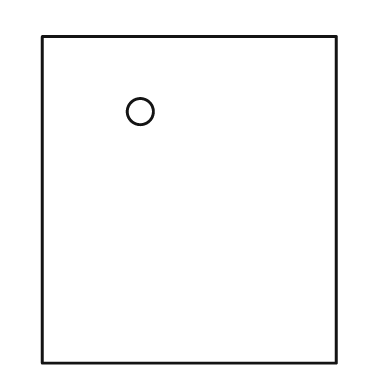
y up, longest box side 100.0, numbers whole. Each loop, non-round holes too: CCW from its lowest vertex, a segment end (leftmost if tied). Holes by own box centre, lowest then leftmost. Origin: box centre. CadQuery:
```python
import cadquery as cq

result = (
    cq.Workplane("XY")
    .moveTo(-45.0, -50.0)
    .lineTo(45.0, -50.0)
    .lineTo(45.0, 50.0)
    .lineTo(-45.0, 50.0)
    .close()
    .moveTo(-15.0, 27.0)
    .circle(4.0)
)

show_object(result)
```